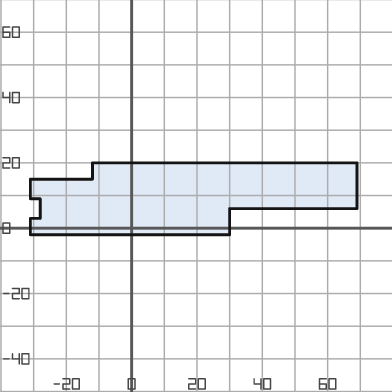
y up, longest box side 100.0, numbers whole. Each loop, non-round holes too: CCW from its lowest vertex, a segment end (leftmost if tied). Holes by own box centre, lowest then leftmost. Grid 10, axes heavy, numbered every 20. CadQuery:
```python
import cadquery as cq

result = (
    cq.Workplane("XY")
    .moveTo(-31.0, -2.0)
    .lineTo(30.0, -2.0)
    .lineTo(30.0, 6.0)
    .lineTo(69.0, 6.0)
    .lineTo(69.0, 20.0)
    .lineTo(-12.0, 20.0)
    .lineTo(-12.0, 15.0)
    .lineTo(-31.0, 15.0)
    .lineTo(-31.0, 9.0)
    .lineTo(-28.0, 9.0)
    .lineTo(-28.0, 3.0)
    .lineTo(-31.0, 3.0)
    .close()
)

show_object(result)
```